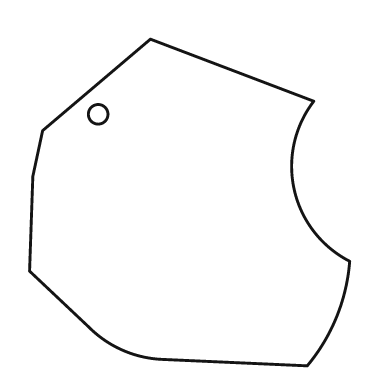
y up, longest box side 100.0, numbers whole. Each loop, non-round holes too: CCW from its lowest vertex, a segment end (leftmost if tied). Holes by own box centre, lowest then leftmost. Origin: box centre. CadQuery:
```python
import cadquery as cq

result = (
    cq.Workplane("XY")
    .moveTo(36.0, -50.0)
    .threePointArc((45.0, -35.0), (49.0, -18.0))
    .threePointArc((32.0, 4.0), (38.0, 31.0))
    .lineTo(-12.0, 50.0)
    .lineTo(-45.0, 22.0)
    .lineTo(-48.0, 8.0)
    .lineTo(-49.0, -21.0)
    .lineTo(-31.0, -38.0)
    .threePointArc((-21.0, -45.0), (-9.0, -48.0))
    .close()
    .moveTo(-28.0, 27.0)
    .circle(3.0)
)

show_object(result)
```